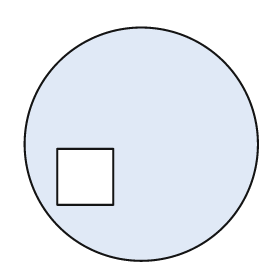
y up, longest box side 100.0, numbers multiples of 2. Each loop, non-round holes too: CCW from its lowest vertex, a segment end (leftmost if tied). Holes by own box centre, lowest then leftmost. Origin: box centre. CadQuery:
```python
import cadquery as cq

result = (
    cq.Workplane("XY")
    .moveTo(0.0, 0.0)
    .circle(50.0)
    .moveTo(-36.0, -26.0)
    .lineTo(-12.0, -26.0)
    .lineTo(-12.0, -2.0)
    .lineTo(-36.0, -2.0)
    .close()
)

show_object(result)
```